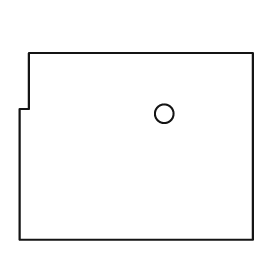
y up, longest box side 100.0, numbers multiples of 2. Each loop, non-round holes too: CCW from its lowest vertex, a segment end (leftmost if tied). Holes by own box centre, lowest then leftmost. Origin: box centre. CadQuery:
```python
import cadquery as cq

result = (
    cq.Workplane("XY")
    .moveTo(-50.0, -40.0)
    .lineTo(50.0, -40.0)
    .lineTo(50.0, 40.0)
    .lineTo(-46.0, 40.0)
    .lineTo(-46.0, 16.0)
    .lineTo(-50.0, 16.0)
    .close()
    .moveTo(12.0, 14.0)
    .circle(4.0)
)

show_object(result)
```